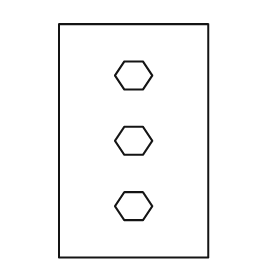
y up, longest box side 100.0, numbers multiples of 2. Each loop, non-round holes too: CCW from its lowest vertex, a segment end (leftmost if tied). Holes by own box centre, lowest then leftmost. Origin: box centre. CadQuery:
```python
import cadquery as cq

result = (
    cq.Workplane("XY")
    .moveTo(-32.0, -50.0)
    .lineTo(32.0, -50.0)
    .lineTo(32.0, 50.0)
    .lineTo(-32.0, 50.0)
    .close()
    .moveTo(-4.0, -34.0)
    .lineTo(4.0, -34.0)
    .lineTo(8.0, -28.0)
    .lineTo(4.0, -22.0)
    .lineTo(-4.0, -22.0)
    .lineTo(-8.0, -28.0)
    .close()
    .moveTo(-4.0, -6.0)
    .lineTo(4.0, -6.0)
    .lineTo(8.0, 0.0)
    .lineTo(4.0, 6.0)
    .lineTo(-4.0, 6.0)
    .lineTo(-8.0, 0.0)
    .close()
    .moveTo(-4.0, 22.0)
    .lineTo(4.0, 22.0)
    .lineTo(8.0, 28.0)
    .lineTo(4.0, 34.0)
    .lineTo(-4.0, 34.0)
    .lineTo(-8.0, 28.0)
    .close()
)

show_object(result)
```